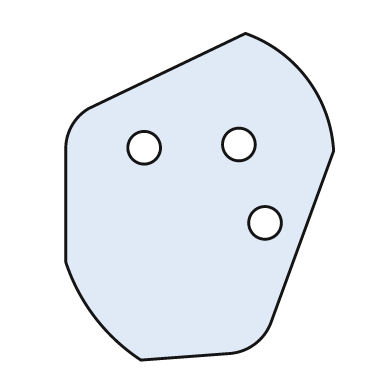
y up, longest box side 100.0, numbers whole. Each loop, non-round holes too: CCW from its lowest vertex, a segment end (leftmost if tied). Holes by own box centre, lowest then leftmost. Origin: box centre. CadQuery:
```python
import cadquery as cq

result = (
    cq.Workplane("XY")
    .moveTo(-18.0, -50.0)
    .lineTo(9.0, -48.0)
    .threePointArc((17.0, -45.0), (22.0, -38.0))
    .lineTo(41.0, 14.0)
    .threePointArc((33.0, 36.0), (14.0, 50.0))
    .lineTo(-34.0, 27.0)
    .threePointArc((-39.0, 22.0), (-41.0, 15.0))
    .lineTo(-41.0, -20.0)
    .threePointArc((-32.0, -37.0), (-18.0, -50.0))
    .close()
    .moveTo(20.0, -8.0)
    .circle(5.0)
    .moveTo(-17.0, 15.0)
    .circle(5.0)
    .moveTo(12.0, 16.0)
    .circle(5.0)
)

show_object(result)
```